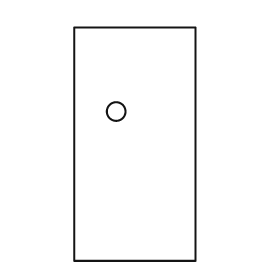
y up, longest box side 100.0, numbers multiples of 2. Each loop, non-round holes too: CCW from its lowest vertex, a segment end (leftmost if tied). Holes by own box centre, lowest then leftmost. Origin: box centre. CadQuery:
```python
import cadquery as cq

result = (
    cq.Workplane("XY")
    .moveTo(-26.0, -50.0)
    .lineTo(26.0, -50.0)
    .lineTo(26.0, 50.0)
    .lineTo(-26.0, 50.0)
    .close()
    .moveTo(-8.0, 14.0)
    .circle(4.0)
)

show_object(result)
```